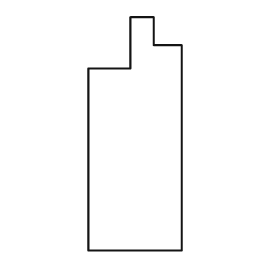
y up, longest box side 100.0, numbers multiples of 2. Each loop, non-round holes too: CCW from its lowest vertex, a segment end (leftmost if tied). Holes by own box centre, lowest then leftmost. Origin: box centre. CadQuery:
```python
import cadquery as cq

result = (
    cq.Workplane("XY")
    .moveTo(-20.0, -50.0)
    .lineTo(20.0, -50.0)
    .lineTo(20.0, 38.0)
    .lineTo(8.0, 38.0)
    .lineTo(8.0, 50.0)
    .lineTo(-2.0, 50.0)
    .lineTo(-2.0, 28.0)
    .lineTo(-20.0, 28.0)
    .close()
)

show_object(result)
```